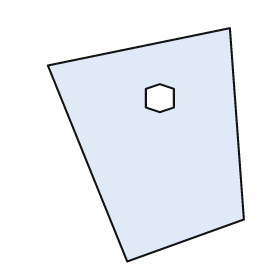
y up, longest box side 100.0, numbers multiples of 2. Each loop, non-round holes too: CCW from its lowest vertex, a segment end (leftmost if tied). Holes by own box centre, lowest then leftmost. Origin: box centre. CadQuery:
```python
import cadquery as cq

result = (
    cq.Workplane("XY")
    .moveTo(-8.0, -50.0)
    .lineTo(42.0, -32.0)
    .lineTo(36.0, 50.0)
    .lineTo(-42.0, 34.0)
    .close()
    .moveTo(6.0, 14.0)
    .lineTo(12.0, 16.0)
    .lineTo(12.0, 24.0)
    .lineTo(6.0, 26.0)
    .lineTo(0.0, 24.0)
    .lineTo(0.0, 16.0)
    .close()
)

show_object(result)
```